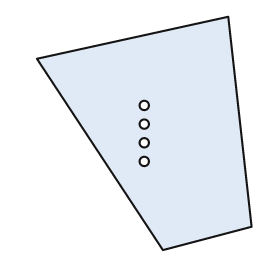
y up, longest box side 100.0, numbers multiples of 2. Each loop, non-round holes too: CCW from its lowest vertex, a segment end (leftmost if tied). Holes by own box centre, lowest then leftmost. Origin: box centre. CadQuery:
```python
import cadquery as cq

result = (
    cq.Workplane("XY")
    .moveTo(8.0, -50.0)
    .lineTo(46.0, -40.0)
    .lineTo(36.0, 50.0)
    .lineTo(-46.0, 32.0)
    .close()
    .moveTo(0.0, -12.0)
    .circle(2.0)
    .moveTo(0.0, -4.0)
    .circle(2.0)
    .moveTo(0.0, 4.0)
    .circle(2.0)
    .moveTo(0.0, 12.0)
    .circle(2.0)
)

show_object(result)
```